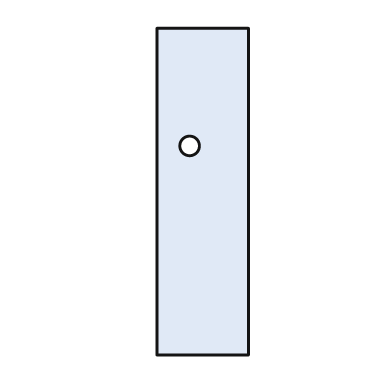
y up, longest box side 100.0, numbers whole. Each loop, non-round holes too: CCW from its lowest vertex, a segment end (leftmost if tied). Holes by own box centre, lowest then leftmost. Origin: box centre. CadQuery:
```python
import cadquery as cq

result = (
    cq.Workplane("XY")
    .moveTo(-14.0, -50.0)
    .lineTo(14.0, -50.0)
    .lineTo(14.0, 50.0)
    .lineTo(-14.0, 50.0)
    .close()
    .moveTo(-4.0, 14.0)
    .circle(3.0)
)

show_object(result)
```